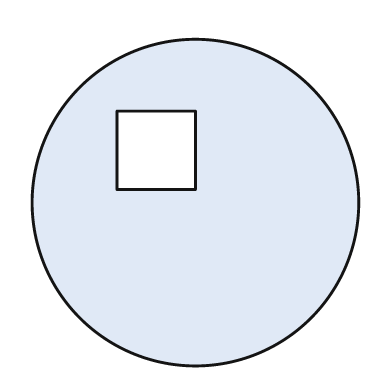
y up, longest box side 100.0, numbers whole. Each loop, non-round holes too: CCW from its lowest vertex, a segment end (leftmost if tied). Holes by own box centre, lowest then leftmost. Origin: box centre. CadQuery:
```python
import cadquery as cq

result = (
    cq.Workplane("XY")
    .moveTo(0.0, 0.0)
    .circle(50.0)
    .moveTo(-24.0, 4.0)
    .lineTo(0.0, 4.0)
    .lineTo(0.0, 28.0)
    .lineTo(-24.0, 28.0)
    .close()
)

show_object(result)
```